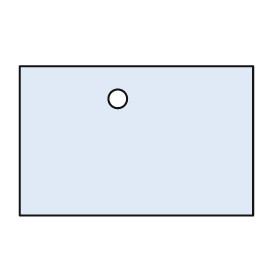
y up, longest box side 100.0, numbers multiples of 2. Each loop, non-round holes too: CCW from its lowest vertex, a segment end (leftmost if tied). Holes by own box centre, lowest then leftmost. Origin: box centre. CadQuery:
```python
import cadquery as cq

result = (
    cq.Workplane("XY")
    .moveTo(-50.0, -32.0)
    .lineTo(50.0, -32.0)
    .lineTo(50.0, 32.0)
    .lineTo(-50.0, 32.0)
    .close()
    .moveTo(-8.0, 18.0)
    .circle(4.0)
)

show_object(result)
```